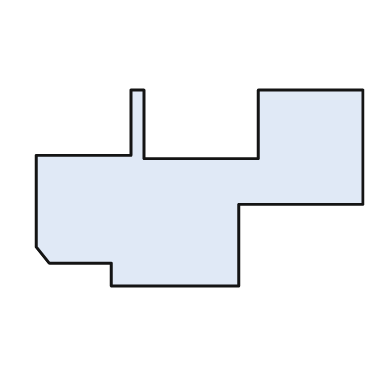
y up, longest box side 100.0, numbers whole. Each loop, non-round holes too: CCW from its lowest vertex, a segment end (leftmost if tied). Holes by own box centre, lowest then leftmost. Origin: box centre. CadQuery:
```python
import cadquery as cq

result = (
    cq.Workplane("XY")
    .moveTo(-27.0, -30.0)
    .lineTo(12.0, -30.0)
    .lineTo(12.0, -5.0)
    .lineTo(50.0, -5.0)
    .lineTo(50.0, 30.0)
    .lineTo(18.0, 30.0)
    .lineTo(18.0, 9.0)
    .lineTo(-17.0, 9.0)
    .lineTo(-17.0, 30.0)
    .lineTo(-21.0, 30.0)
    .lineTo(-21.0, 10.0)
    .lineTo(-50.0, 10.0)
    .lineTo(-50.0, -18.0)
    .lineTo(-46.0, -23.0)
    .lineTo(-27.0, -23.0)
    .close()
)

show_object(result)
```